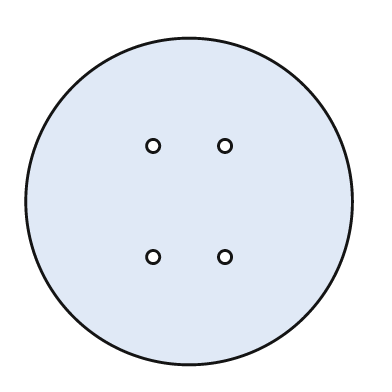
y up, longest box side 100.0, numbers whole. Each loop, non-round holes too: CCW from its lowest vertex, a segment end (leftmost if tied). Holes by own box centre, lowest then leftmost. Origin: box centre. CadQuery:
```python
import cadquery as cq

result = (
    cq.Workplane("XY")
    .moveTo(0.0, 0.0)
    .circle(50.0)
    .moveTo(-11.0, -17.0)
    .circle(2.0)
    .moveTo(11.0, -17.0)
    .circle(2.0)
    .moveTo(-11.0, 17.0)
    .circle(2.0)
    .moveTo(11.0, 17.0)
    .circle(2.0)
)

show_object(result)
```